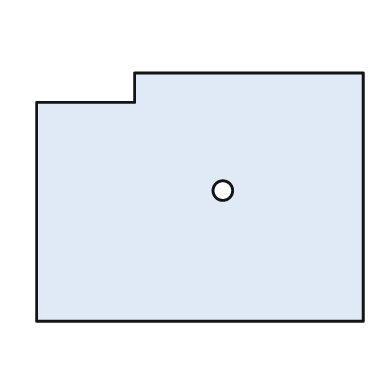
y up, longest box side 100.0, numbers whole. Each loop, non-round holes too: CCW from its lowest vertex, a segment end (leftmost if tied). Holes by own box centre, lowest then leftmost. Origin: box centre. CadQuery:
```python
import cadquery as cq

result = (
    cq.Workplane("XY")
    .moveTo(-50.0, -38.0)
    .lineTo(50.0, -38.0)
    .lineTo(50.0, 38.0)
    .lineTo(-20.0, 38.0)
    .lineTo(-20.0, 29.0)
    .lineTo(-50.0, 29.0)
    .close()
    .moveTo(7.0, 2.0)
    .circle(3.0)
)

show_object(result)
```